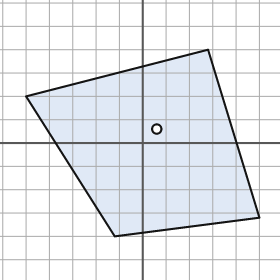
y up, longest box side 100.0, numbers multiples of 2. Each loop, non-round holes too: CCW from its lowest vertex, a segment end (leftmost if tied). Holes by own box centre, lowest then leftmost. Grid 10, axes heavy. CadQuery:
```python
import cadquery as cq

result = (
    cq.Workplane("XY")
    .moveTo(-12.0, -40.0)
    .lineTo(50.0, -32.0)
    .lineTo(28.0, 40.0)
    .lineTo(-50.0, 20.0)
    .close()
    .moveTo(6.0, 6.0)
    .circle(2.0)
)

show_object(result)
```